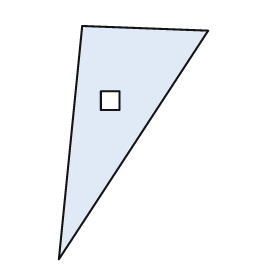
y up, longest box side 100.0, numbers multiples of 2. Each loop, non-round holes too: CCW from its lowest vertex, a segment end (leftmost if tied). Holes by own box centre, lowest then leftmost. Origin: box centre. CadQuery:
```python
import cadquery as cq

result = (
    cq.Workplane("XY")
    .moveTo(-32.0, -50.0)
    .lineTo(32.0, 48.0)
    .lineTo(-22.0, 50.0)
    .close()
    .moveTo(-14.0, 14.0)
    .lineTo(-6.0, 14.0)
    .lineTo(-6.0, 22.0)
    .lineTo(-14.0, 22.0)
    .close()
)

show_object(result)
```